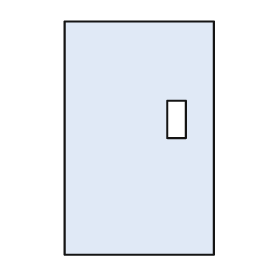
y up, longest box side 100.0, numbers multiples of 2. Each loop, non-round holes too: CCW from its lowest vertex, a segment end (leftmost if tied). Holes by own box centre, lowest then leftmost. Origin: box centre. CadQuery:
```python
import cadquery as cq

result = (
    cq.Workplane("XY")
    .moveTo(-32.0, -50.0)
    .lineTo(32.0, -50.0)
    .lineTo(32.0, 50.0)
    .lineTo(-32.0, 50.0)
    .close()
    .moveTo(12.0, 0.0)
    .lineTo(20.0, 0.0)
    .lineTo(20.0, 16.0)
    .lineTo(12.0, 16.0)
    .close()
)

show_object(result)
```